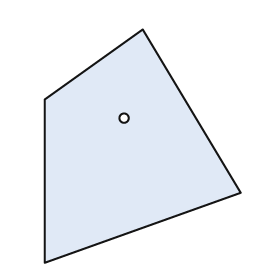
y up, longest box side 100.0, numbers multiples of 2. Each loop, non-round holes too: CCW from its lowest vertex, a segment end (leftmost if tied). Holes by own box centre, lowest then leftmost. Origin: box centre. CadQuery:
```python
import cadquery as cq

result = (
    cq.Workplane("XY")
    .moveTo(-42.0, -50.0)
    .lineTo(42.0, -20.0)
    .lineTo(0.0, 50.0)
    .lineTo(-42.0, 20.0)
    .close()
    .moveTo(-8.0, 12.0)
    .circle(2.0)
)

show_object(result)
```